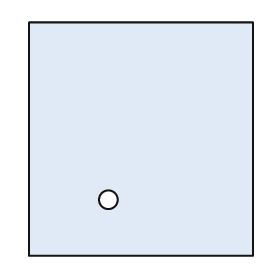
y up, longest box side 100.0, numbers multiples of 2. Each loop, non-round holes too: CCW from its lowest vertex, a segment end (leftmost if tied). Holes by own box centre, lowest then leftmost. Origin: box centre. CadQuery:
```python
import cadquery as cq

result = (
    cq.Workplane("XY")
    .moveTo(-48.0, -50.0)
    .lineTo(48.0, -50.0)
    .lineTo(48.0, 50.0)
    .lineTo(-48.0, 50.0)
    .close()
    .moveTo(-14.0, -26.0)
    .circle(4.0)
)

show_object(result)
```